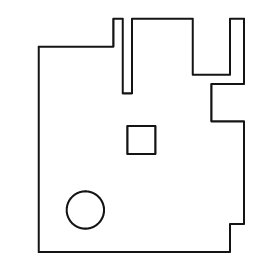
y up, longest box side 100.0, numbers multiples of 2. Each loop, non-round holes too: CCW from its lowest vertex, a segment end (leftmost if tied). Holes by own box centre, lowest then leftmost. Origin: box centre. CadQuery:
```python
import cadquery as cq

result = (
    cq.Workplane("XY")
    .moveTo(-44.0, -50.0)
    .lineTo(38.0, -50.0)
    .lineTo(38.0, -38.0)
    .lineTo(44.0, -38.0)
    .lineTo(44.0, 6.0)
    .lineTo(30.0, 6.0)
    .lineTo(30.0, 22.0)
    .lineTo(44.0, 22.0)
    .lineTo(44.0, 50.0)
    .lineTo(38.0, 50.0)
    .lineTo(38.0, 26.0)
    .lineTo(22.0, 26.0)
    .lineTo(22.0, 50.0)
    .lineTo(-4.0, 50.0)
    .lineTo(-4.0, 18.0)
    .lineTo(-8.0, 18.0)
    .lineTo(-8.0, 50.0)
    .lineTo(-12.0, 50.0)
    .lineTo(-12.0, 38.0)
    .lineTo(-44.0, 38.0)
    .close()
    .moveTo(-24.0, -32.0)
    .circle(8.0)
    .moveTo(-6.0, -8.0)
    .lineTo(6.0, -8.0)
    .lineTo(6.0, 4.0)
    .lineTo(-6.0, 4.0)
    .close()
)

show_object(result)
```